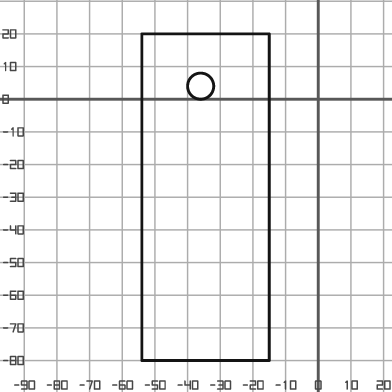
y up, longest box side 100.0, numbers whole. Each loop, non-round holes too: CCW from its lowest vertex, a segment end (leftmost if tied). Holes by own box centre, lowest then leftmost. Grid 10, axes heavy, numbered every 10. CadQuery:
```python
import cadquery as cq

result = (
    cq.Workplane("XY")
    .moveTo(-54.0, -80.0)
    .lineTo(-15.0, -80.0)
    .lineTo(-15.0, 20.0)
    .lineTo(-54.0, 20.0)
    .close()
    .moveTo(-36.0, 4.0)
    .circle(4.0)
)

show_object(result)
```